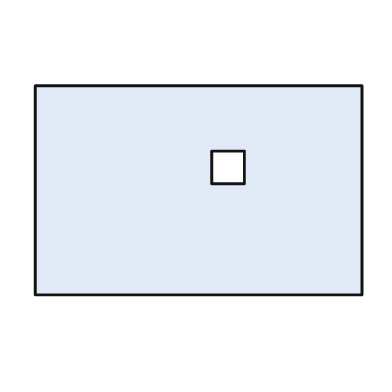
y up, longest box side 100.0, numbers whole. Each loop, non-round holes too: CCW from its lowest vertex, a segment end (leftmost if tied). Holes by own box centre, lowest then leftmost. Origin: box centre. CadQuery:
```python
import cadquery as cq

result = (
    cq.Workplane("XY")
    .moveTo(-50.0, -32.0)
    .lineTo(50.0, -32.0)
    .lineTo(50.0, 32.0)
    .lineTo(-50.0, 32.0)
    .close()
    .moveTo(4.0, 2.0)
    .lineTo(14.0, 2.0)
    .lineTo(14.0, 12.0)
    .lineTo(4.0, 12.0)
    .close()
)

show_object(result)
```